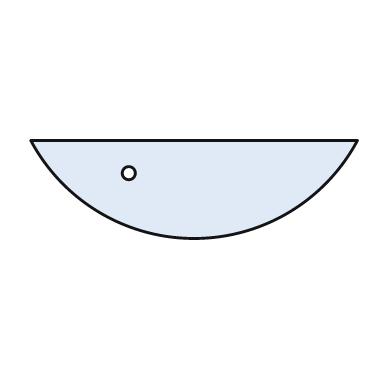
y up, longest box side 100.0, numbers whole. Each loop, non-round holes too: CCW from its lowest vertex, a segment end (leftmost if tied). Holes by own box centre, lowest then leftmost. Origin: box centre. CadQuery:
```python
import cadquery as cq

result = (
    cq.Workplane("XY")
    .moveTo(-50.0, 15.0)
    .threePointArc((0.0, -15.0), (50.0, 15.0))
    .close()
    .moveTo(-20.0, 5.0)
    .circle(2.0)
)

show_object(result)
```